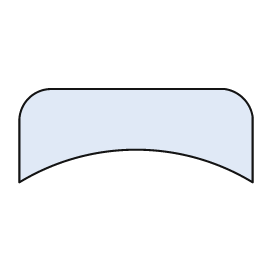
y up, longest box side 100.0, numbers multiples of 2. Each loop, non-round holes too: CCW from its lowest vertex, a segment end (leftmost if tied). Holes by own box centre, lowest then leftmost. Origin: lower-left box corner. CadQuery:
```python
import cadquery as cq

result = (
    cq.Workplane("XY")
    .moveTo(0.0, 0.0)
    .threePointArc((50.0, 14.0), (100.0, 0.0))
    .lineTo(100.0, 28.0)
    .threePointArc((96.0, 36.0), (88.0, 40.0))
    .lineTo(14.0, 40.0)
    .threePointArc((4.0, 36.0), (0.0, 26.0))
    .close()
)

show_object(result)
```